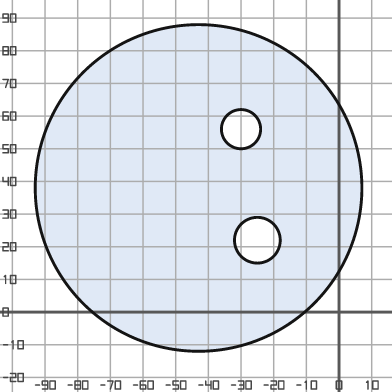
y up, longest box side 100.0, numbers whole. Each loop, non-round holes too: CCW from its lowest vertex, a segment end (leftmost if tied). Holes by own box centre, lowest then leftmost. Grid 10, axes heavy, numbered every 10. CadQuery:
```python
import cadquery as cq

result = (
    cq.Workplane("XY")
    .moveTo(-43.0, 38.0)
    .circle(50.0)
    .moveTo(-25.0, 22.0)
    .circle(7.0)
    .moveTo(-30.0, 56.0)
    .circle(6.0)
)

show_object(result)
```